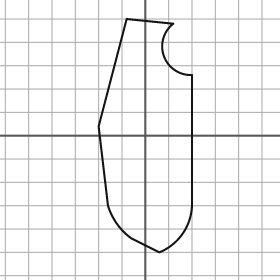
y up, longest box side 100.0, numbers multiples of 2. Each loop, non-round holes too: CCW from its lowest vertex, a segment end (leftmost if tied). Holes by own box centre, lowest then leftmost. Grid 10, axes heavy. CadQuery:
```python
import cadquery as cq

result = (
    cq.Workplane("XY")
    .moveTo(6.0, -50.0)
    .threePointArc((16.0, -42.0), (20.0, -30.0))
    .lineTo(20.0, 26.0)
    .threePointArc((8.0, 34.0), (12.0, 48.0))
    .lineTo(-8.0, 50.0)
    .lineTo(-20.0, 4.0)
    .lineTo(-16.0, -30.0)
    .threePointArc((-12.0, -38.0), (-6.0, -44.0))
    .close()
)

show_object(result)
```